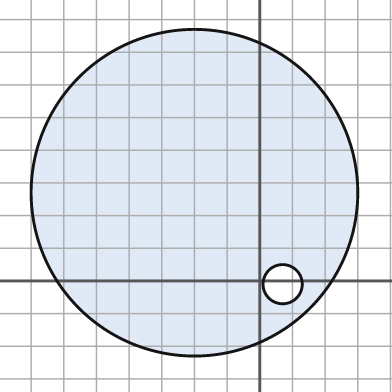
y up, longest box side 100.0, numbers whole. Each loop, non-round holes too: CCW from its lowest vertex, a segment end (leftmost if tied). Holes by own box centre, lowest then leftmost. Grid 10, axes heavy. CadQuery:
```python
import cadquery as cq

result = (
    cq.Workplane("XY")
    .moveTo(-20.0, 27.0)
    .circle(50.0)
    .moveTo(7.0, -1.0)
    .circle(6.0)
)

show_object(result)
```